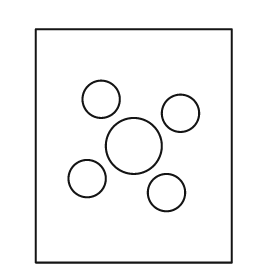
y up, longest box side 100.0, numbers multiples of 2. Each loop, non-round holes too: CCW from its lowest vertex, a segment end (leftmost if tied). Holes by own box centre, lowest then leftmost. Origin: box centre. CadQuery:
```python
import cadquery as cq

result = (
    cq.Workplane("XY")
    .moveTo(-42.0, -50.0)
    .lineTo(42.0, -50.0)
    .lineTo(42.0, 50.0)
    .lineTo(-42.0, 50.0)
    .close()
    .moveTo(14.0, -20.0)
    .circle(8.0)
    .moveTo(-20.0, -14.0)
    .circle(8.0)
    .moveTo(0.0, 0.0)
    .circle(12.0)
    .moveTo(20.0, 14.0)
    .circle(8.0)
    .moveTo(-14.0, 20.0)
    .circle(8.0)
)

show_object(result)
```